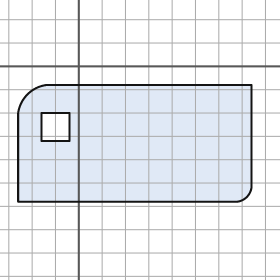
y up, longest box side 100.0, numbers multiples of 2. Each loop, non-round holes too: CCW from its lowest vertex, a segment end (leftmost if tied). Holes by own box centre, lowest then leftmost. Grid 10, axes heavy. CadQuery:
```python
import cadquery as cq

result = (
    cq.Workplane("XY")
    .moveTo(-26.0, -58.0)
    .lineTo(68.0, -58.0)
    .threePointArc((72.0, -56.0), (74.0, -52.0))
    .lineTo(74.0, -8.0)
    .lineTo(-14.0, -8.0)
    .threePointArc((-22.0, -12.0), (-26.0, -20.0))
    .close()
    .moveTo(-16.0, -32.0)
    .lineTo(-4.0, -32.0)
    .lineTo(-4.0, -20.0)
    .lineTo(-16.0, -20.0)
    .close()
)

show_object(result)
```